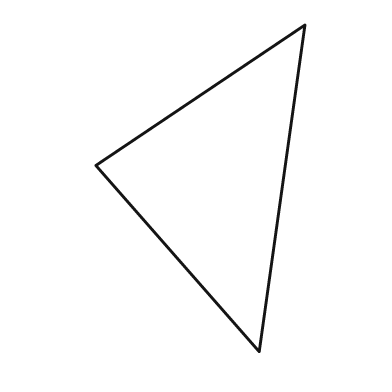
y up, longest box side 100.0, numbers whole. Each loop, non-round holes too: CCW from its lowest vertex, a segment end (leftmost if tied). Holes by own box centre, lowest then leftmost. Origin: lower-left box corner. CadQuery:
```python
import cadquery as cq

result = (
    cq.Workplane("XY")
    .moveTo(50.0, 0.0)
    .lineTo(64.0, 100.0)
    .lineTo(0.0, 57.0)
    .close()
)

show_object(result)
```